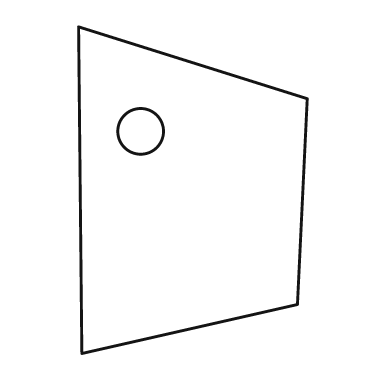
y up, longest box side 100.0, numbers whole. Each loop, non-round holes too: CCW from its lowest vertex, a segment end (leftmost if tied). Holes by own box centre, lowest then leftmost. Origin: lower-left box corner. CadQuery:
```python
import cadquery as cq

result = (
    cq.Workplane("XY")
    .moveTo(1.0, 0.0)
    .lineTo(67.0, 15.0)
    .lineTo(70.0, 78.0)
    .lineTo(0.0, 100.0)
    .close()
    .moveTo(19.0, 68.0)
    .circle(7.0)
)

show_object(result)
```